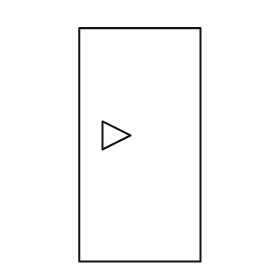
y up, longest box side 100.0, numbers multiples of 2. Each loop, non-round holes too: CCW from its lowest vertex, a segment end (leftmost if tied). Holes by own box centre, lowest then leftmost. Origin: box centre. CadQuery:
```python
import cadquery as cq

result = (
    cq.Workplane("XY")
    .moveTo(-26.0, -50.0)
    .lineTo(26.0, -50.0)
    .lineTo(26.0, 50.0)
    .lineTo(-26.0, 50.0)
    .close()
    .moveTo(-16.0, -2.0)
    .lineTo(-4.0, 4.0)
    .lineTo(-16.0, 10.0)
    .close()
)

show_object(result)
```